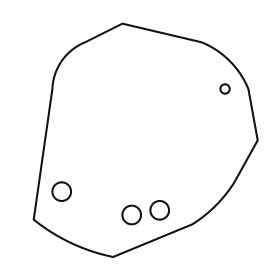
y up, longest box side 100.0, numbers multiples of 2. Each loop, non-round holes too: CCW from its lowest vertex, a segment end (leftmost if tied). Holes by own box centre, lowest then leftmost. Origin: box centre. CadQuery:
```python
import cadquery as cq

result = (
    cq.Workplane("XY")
    .moveTo(-14.0, -50.0)
    .lineTo(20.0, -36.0)
    .threePointArc((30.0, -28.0), (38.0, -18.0))
    .lineTo(48.0, 0.0)
    .lineTo(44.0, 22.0)
    .threePointArc((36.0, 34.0), (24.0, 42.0))
    .lineTo(-10.0, 50.0)
    .lineTo(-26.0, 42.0)
    .threePointArc((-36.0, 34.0), (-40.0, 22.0))
    .lineTo(-48.0, -34.0)
    .threePointArc((-32.0, -44.0), (-14.0, -50.0))
    .close()
    .moveTo(-6.0, -32.0)
    .circle(4.0)
    .moveTo(6.0, -30.0)
    .circle(4.0)
    .moveTo(-36.0, -22.0)
    .circle(4.0)
    .moveTo(34.0, 22.0)
    .circle(2.0)
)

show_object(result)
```